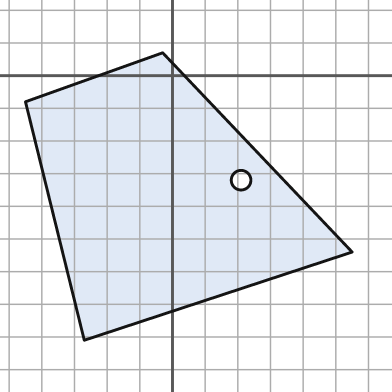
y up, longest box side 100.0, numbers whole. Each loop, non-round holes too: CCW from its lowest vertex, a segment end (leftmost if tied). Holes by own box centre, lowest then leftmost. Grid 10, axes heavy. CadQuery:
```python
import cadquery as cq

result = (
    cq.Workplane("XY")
    .moveTo(-27.0, -81.0)
    .lineTo(55.0, -54.0)
    .lineTo(-3.0, 7.0)
    .lineTo(-45.0, -8.0)
    .close()
    .moveTo(21.0, -32.0)
    .circle(3.0)
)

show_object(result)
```